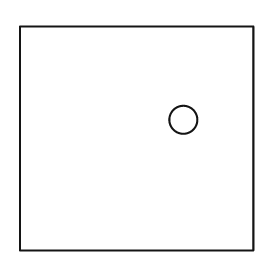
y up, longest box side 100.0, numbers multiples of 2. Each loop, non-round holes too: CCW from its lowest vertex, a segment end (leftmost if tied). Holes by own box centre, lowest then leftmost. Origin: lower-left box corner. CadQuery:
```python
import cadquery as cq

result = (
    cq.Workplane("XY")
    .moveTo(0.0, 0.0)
    .lineTo(100.0, 0.0)
    .lineTo(100.0, 96.0)
    .lineTo(0.0, 96.0)
    .close()
    .moveTo(70.0, 56.0)
    .circle(6.0)
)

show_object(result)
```